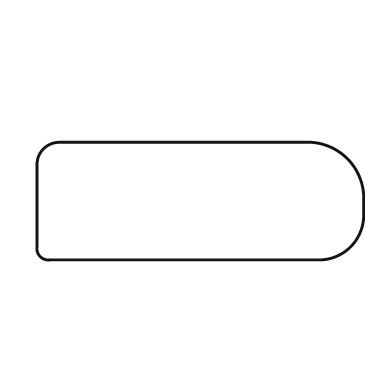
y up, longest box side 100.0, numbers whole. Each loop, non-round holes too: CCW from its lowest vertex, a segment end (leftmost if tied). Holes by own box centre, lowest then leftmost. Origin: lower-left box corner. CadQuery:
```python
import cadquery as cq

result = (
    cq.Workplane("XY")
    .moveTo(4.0, 0.0)
    .lineTo(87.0, 0.0)
    .threePointArc((96.0, 4.0), (100.0, 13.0))
    .lineTo(100.0, 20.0)
    .threePointArc((95.0, 31.0), (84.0, 36.0))
    .lineTo(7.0, 36.0)
    .threePointArc((2.0, 34.0), (0.0, 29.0))
    .lineTo(0.0, 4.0)
    .threePointArc((1.0, 1.0), (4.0, 0.0))
    .close()
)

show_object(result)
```